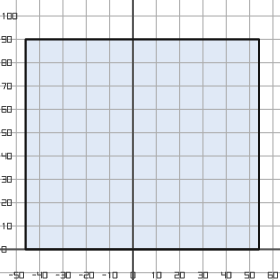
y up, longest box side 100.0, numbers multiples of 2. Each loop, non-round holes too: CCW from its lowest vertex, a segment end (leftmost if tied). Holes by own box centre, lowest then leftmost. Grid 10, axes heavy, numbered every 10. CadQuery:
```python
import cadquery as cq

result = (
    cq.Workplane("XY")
    .moveTo(-46.0, 0.0)
    .lineTo(54.0, 0.0)
    .lineTo(54.0, 90.0)
    .lineTo(-46.0, 90.0)
    .close()
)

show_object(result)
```